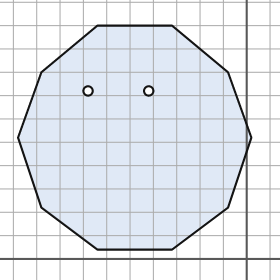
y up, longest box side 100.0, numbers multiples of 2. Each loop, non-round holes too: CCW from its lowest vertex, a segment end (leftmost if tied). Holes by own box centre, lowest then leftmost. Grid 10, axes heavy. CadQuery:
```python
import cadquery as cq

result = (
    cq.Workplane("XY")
    .moveTo(-64.0, 4.0)
    .lineTo(-32.0, 4.0)
    .lineTo(-8.0, 22.0)
    .lineTo(2.0, 52.0)
    .lineTo(-8.0, 80.0)
    .lineTo(-32.0, 100.0)
    .lineTo(-64.0, 100.0)
    .lineTo(-88.0, 80.0)
    .lineTo(-98.0, 52.0)
    .lineTo(-88.0, 22.0)
    .close()
    .moveTo(-68.0, 72.0)
    .circle(2.0)
    .moveTo(-42.0, 72.0)
    .circle(2.0)
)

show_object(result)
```